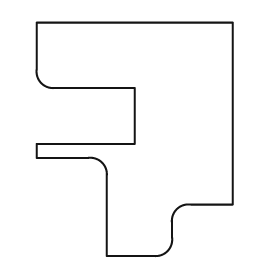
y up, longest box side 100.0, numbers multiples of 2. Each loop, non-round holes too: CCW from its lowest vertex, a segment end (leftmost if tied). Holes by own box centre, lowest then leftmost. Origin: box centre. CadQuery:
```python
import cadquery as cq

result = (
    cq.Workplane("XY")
    .moveTo(-12.0, -50.0)
    .lineTo(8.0, -50.0)
    .threePointArc((14.0, -48.0), (16.0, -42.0))
    .lineTo(16.0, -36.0)
    .threePointArc((18.0, -30.0), (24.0, -28.0))
    .lineTo(42.0, -28.0)
    .lineTo(42.0, 50.0)
    .lineTo(-42.0, 50.0)
    .lineTo(-42.0, 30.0)
    .threePointArc((-40.0, 24.0), (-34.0, 22.0))
    .lineTo(0.0, 22.0)
    .lineTo(0.0, -2.0)
    .lineTo(-42.0, -2.0)
    .lineTo(-42.0, -8.0)
    .lineTo(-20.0, -8.0)
    .threePointArc((-14.0, -10.0), (-12.0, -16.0))
    .close()
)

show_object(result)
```